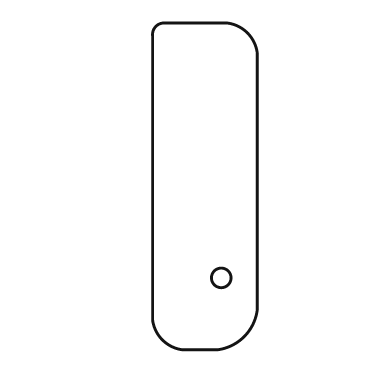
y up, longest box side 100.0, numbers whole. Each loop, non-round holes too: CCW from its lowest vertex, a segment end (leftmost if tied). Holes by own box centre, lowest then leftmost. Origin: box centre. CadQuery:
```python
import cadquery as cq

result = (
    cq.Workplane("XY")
    .moveTo(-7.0, -50.0)
    .lineTo(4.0, -50.0)
    .threePointArc((12.0, -46.0), (16.0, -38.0))
    .lineTo(16.0, 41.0)
    .threePointArc((13.0, 47.0), (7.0, 50.0))
    .lineTo(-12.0, 50.0)
    .threePointArc((-15.0, 49.0), (-16.0, 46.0))
    .lineTo(-16.0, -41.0)
    .threePointArc((-13.0, -47.0), (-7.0, -50.0))
    .close()
    .moveTo(5.0, -28.0)
    .circle(3.0)
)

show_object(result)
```